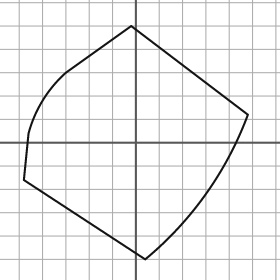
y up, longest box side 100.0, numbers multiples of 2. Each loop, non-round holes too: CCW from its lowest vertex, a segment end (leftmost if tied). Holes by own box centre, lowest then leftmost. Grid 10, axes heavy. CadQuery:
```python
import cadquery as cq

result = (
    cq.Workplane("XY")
    .moveTo(4.0, -50.0)
    .threePointArc((30.0, -22.0), (48.0, 12.0))
    .lineTo(-2.0, 50.0)
    .lineTo(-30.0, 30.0)
    .threePointArc((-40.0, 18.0), (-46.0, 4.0))
    .lineTo(-48.0, -16.0)
    .close()
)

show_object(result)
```